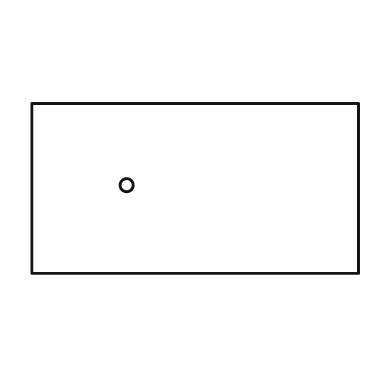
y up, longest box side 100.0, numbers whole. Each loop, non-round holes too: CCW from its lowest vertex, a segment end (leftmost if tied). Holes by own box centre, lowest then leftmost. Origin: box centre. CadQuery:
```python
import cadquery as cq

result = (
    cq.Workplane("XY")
    .moveTo(-50.0, -26.0)
    .lineTo(50.0, -26.0)
    .lineTo(50.0, 26.0)
    .lineTo(-50.0, 26.0)
    .close()
    .moveTo(-21.0, 1.0)
    .circle(2.0)
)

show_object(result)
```